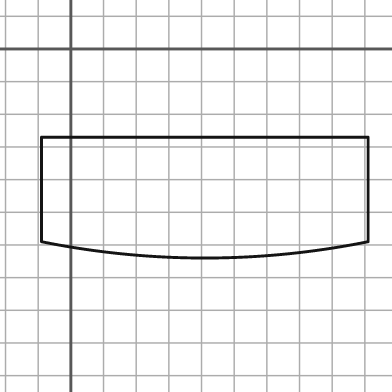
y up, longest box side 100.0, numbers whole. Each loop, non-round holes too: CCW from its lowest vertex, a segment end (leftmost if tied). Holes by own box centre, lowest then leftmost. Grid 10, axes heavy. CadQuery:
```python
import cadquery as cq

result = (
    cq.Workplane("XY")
    .moveTo(-9.0, -59.0)
    .threePointArc((41.0, -64.0), (91.0, -59.0))
    .lineTo(91.0, -27.0)
    .lineTo(-9.0, -27.0)
    .close()
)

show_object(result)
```